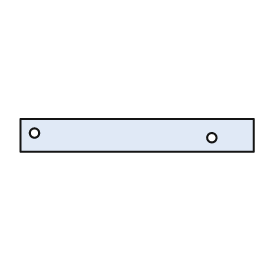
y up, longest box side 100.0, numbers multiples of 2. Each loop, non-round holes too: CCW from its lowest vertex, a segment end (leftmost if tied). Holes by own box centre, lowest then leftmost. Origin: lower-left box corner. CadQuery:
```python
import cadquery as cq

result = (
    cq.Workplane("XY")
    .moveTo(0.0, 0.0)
    .lineTo(100.0, 0.0)
    .lineTo(100.0, 14.0)
    .lineTo(0.0, 14.0)
    .close()
    .moveTo(82.0, 6.0)
    .circle(2.0)
    .moveTo(6.0, 8.0)
    .circle(2.0)
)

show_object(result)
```